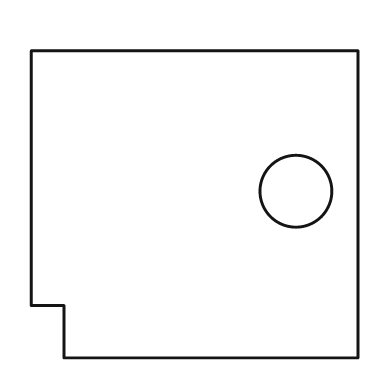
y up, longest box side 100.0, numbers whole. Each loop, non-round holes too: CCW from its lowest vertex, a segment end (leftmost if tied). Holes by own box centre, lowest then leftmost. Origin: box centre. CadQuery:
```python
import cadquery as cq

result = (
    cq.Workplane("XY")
    .moveTo(-40.0, -47.0)
    .lineTo(50.0, -47.0)
    .lineTo(50.0, 47.0)
    .lineTo(-50.0, 47.0)
    .lineTo(-50.0, -31.0)
    .lineTo(-40.0, -31.0)
    .close()
    .moveTo(31.0, 4.0)
    .circle(11.0)
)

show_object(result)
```